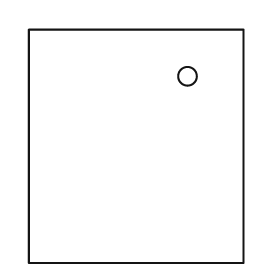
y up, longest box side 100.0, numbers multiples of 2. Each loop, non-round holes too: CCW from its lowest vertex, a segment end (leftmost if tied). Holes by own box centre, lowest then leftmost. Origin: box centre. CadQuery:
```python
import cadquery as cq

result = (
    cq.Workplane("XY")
    .moveTo(-46.0, -50.0)
    .lineTo(46.0, -50.0)
    .lineTo(46.0, 50.0)
    .lineTo(-46.0, 50.0)
    .close()
    .moveTo(22.0, 30.0)
    .circle(4.0)
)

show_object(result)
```